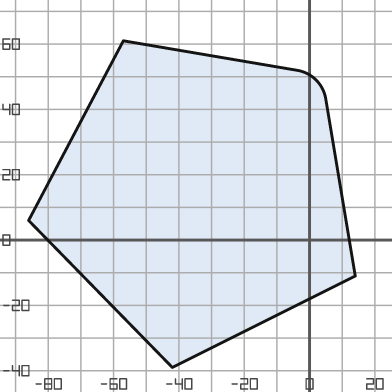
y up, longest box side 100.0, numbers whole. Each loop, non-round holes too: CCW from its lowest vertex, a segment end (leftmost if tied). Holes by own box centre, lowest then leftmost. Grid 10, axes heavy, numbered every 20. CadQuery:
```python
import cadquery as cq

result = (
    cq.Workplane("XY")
    .moveTo(-42.0, -39.0)
    .lineTo(14.0, -11.0)
    .lineTo(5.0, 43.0)
    .threePointArc((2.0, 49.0), (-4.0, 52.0))
    .lineTo(-57.0, 61.0)
    .lineTo(-86.0, 6.0)
    .close()
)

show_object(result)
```